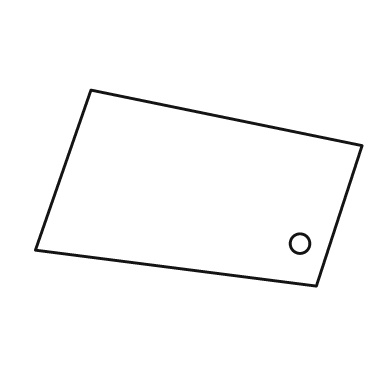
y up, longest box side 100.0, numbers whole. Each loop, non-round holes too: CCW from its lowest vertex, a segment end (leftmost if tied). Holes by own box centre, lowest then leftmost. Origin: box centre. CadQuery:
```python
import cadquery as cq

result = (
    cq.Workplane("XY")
    .moveTo(36.0, -30.0)
    .lineTo(50.0, 13.0)
    .lineTo(-33.0, 30.0)
    .lineTo(-50.0, -19.0)
    .close()
    .moveTo(31.0, -17.0)
    .circle(3.0)
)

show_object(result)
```